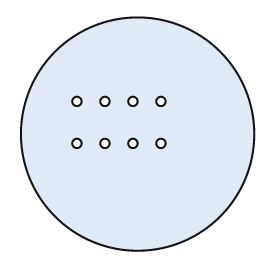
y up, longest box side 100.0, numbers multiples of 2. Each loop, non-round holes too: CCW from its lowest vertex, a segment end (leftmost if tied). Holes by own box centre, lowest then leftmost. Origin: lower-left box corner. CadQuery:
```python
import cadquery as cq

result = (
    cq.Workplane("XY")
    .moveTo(50.0, 50.0)
    .circle(50.0)
    .moveTo(24.0, 46.0)
    .circle(2.0)
    .moveTo(36.0, 46.0)
    .circle(2.0)
    .moveTo(48.0, 46.0)
    .circle(2.0)
    .moveTo(60.0, 46.0)
    .circle(2.0)
    .moveTo(24.0, 64.0)
    .circle(2.0)
    .moveTo(36.0, 64.0)
    .circle(2.0)
    .moveTo(48.0, 64.0)
    .circle(2.0)
    .moveTo(60.0, 64.0)
    .circle(2.0)
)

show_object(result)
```